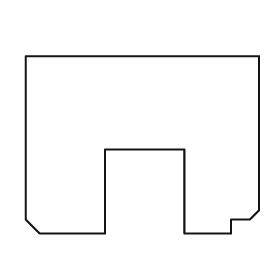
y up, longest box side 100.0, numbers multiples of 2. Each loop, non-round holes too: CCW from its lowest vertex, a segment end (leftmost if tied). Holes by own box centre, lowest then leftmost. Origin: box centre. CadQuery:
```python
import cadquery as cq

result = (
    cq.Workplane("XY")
    .moveTo(-44.0, -38.0)
    .lineTo(-16.0, -38.0)
    .lineTo(-16.0, -2.0)
    .lineTo(18.0, -2.0)
    .lineTo(18.0, -38.0)
    .lineTo(38.0, -38.0)
    .lineTo(38.0, -32.0)
    .lineTo(46.0, -32.0)
    .lineTo(50.0, -28.0)
    .lineTo(50.0, 38.0)
    .lineTo(-50.0, 38.0)
    .lineTo(-50.0, -32.0)
    .close()
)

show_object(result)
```